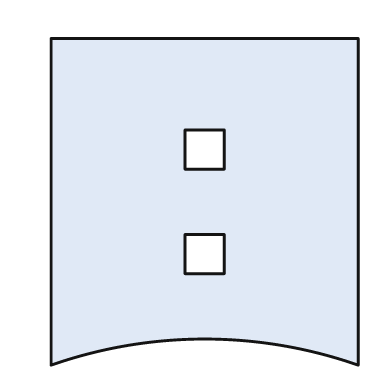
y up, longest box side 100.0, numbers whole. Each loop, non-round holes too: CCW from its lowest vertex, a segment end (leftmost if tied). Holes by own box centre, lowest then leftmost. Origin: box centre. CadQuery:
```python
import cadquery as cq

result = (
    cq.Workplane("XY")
    .moveTo(-47.0, -50.0)
    .threePointArc((0.0, -42.0), (47.0, -50.0))
    .lineTo(47.0, 50.0)
    .lineTo(-47.0, 50.0)
    .close()
    .moveTo(-6.0, -22.0)
    .lineTo(6.0, -22.0)
    .lineTo(6.0, -10.0)
    .lineTo(-6.0, -10.0)
    .close()
    .moveTo(-6.0, 10.0)
    .lineTo(6.0, 10.0)
    .lineTo(6.0, 22.0)
    .lineTo(-6.0, 22.0)
    .close()
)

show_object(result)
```